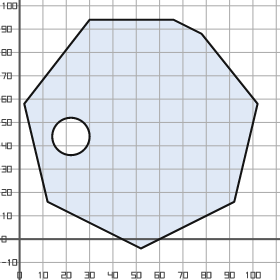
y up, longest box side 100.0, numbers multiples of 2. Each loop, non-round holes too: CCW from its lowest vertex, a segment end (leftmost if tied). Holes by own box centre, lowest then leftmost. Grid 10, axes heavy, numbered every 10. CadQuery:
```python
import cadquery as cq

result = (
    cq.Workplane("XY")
    .moveTo(52.0, -4.0)
    .lineTo(92.0, 16.0)
    .lineTo(102.0, 58.0)
    .lineTo(78.0, 88.0)
    .lineTo(66.0, 94.0)
    .lineTo(30.0, 94.0)
    .lineTo(2.0, 58.0)
    .lineTo(12.0, 16.0)
    .close()
    .moveTo(22.0, 44.0)
    .circle(8.0)
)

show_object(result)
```